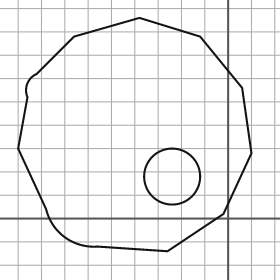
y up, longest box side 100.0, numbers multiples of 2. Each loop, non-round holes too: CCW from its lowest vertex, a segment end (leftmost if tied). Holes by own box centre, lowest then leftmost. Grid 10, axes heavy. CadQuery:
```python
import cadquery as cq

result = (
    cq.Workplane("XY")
    .moveTo(-26.0, -14.0)
    .lineTo(-2.0, 2.0)
    .lineTo(10.0, 28.0)
    .lineTo(6.0, 56.0)
    .lineTo(-12.0, 78.0)
    .lineTo(-38.0, 86.0)
    .lineTo(-66.0, 78.0)
    .lineTo(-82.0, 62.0)
    .threePointArc((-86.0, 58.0), (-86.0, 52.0))
    .lineTo(-90.0, 30.0)
    .lineTo(-78.0, 4.0)
    .threePointArc((-70.0, -8.0), (-56.0, -12.0))
    .close()
    .moveTo(-24.0, 18.0)
    .circle(12.0)
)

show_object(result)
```